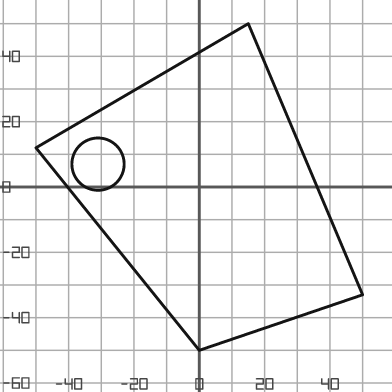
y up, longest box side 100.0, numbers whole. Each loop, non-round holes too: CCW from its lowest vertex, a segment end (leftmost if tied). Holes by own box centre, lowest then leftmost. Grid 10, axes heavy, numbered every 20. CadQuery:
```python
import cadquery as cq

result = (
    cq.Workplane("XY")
    .moveTo(0.0, -50.0)
    .lineTo(50.0, -33.0)
    .lineTo(15.0, 50.0)
    .lineTo(-50.0, 12.0)
    .close()
    .moveTo(-31.0, 7.0)
    .circle(8.0)
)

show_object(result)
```